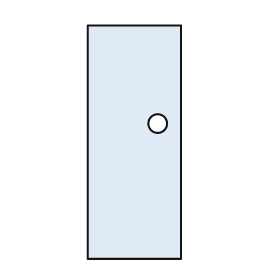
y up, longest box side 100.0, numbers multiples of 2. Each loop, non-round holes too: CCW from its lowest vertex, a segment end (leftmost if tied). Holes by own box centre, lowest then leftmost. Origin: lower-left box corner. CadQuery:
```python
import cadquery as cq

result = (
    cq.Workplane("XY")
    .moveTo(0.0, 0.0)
    .lineTo(40.0, 0.0)
    .lineTo(40.0, 100.0)
    .lineTo(0.0, 100.0)
    .close()
    .moveTo(30.0, 58.0)
    .circle(4.0)
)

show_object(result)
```